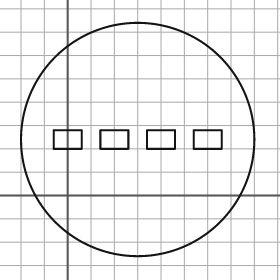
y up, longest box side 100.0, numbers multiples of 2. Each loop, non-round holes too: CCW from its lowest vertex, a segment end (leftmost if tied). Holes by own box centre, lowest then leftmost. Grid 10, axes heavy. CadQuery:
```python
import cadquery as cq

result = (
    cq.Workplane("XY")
    .moveTo(30.0, 24.0)
    .circle(50.0)
    .moveTo(-6.0, 20.0)
    .lineTo(6.0, 20.0)
    .lineTo(6.0, 28.0)
    .lineTo(-6.0, 28.0)
    .close()
    .moveTo(14.0, 20.0)
    .lineTo(26.0, 20.0)
    .lineTo(26.0, 28.0)
    .lineTo(14.0, 28.0)
    .close()
    .moveTo(34.0, 20.0)
    .lineTo(46.0, 20.0)
    .lineTo(46.0, 28.0)
    .lineTo(34.0, 28.0)
    .close()
    .moveTo(54.0, 20.0)
    .lineTo(66.0, 20.0)
    .lineTo(66.0, 28.0)
    .lineTo(54.0, 28.0)
    .close()
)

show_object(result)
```